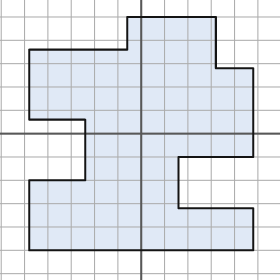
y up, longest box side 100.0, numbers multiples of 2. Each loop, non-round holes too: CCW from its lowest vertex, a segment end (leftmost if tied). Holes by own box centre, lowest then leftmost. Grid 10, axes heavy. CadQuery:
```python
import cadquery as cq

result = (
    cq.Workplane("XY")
    .moveTo(-48.0, -50.0)
    .lineTo(48.0, -50.0)
    .lineTo(48.0, -32.0)
    .lineTo(16.0, -32.0)
    .lineTo(16.0, -10.0)
    .lineTo(48.0, -10.0)
    .lineTo(48.0, 28.0)
    .lineTo(32.0, 28.0)
    .lineTo(32.0, 50.0)
    .lineTo(-6.0, 50.0)
    .lineTo(-6.0, 36.0)
    .lineTo(-48.0, 36.0)
    .lineTo(-48.0, 6.0)
    .lineTo(-24.0, 6.0)
    .lineTo(-24.0, -20.0)
    .lineTo(-48.0, -20.0)
    .close()
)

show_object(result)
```